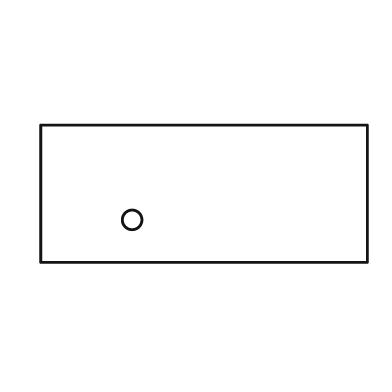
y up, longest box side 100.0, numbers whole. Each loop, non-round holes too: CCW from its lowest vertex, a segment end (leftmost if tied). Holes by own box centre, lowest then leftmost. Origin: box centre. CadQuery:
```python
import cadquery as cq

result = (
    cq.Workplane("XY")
    .moveTo(-50.0, -21.0)
    .lineTo(50.0, -21.0)
    .lineTo(50.0, 21.0)
    .lineTo(-50.0, 21.0)
    .close()
    .moveTo(-22.0, -8.0)
    .circle(3.0)
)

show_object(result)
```